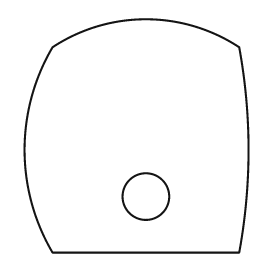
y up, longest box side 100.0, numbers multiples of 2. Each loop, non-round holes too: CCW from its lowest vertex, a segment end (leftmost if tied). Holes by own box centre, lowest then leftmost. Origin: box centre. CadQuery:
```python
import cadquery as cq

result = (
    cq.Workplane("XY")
    .moveTo(-36.0, -50.0)
    .lineTo(44.0, -50.0)
    .threePointArc((48.0, -6.0), (44.0, 38.0))
    .threePointArc((4.0, 50.0), (-36.0, 38.0))
    .threePointArc((-48.0, -6.0), (-36.0, -50.0))
    .close()
    .moveTo(4.0, -26.0)
    .circle(10.0)
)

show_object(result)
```